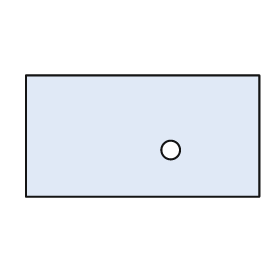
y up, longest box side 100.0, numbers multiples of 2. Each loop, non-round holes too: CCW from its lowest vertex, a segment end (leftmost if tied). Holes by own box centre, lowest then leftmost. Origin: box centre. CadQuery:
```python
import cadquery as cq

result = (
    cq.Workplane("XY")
    .moveTo(-50.0, -26.0)
    .lineTo(50.0, -26.0)
    .lineTo(50.0, 26.0)
    .lineTo(-50.0, 26.0)
    .close()
    .moveTo(12.0, -6.0)
    .circle(4.0)
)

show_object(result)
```